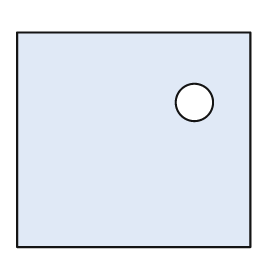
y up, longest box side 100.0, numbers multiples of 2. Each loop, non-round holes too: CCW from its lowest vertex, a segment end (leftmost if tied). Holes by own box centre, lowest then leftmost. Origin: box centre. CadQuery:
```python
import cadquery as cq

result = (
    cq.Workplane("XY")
    .moveTo(-50.0, -46.0)
    .lineTo(50.0, -46.0)
    .lineTo(50.0, 46.0)
    .lineTo(-50.0, 46.0)
    .close()
    .moveTo(26.0, 16.0)
    .circle(8.0)
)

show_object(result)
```